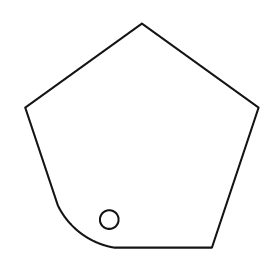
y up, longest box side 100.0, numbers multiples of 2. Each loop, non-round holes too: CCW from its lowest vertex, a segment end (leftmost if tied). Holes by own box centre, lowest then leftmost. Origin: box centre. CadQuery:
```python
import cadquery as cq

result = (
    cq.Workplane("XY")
    .moveTo(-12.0, -48.0)
    .lineTo(30.0, -48.0)
    .lineTo(50.0, 12.0)
    .lineTo(0.0, 48.0)
    .lineTo(-50.0, 12.0)
    .lineTo(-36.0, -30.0)
    .threePointArc((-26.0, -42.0), (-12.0, -48.0))
    .close()
    .moveTo(-14.0, -36.0)
    .circle(4.0)
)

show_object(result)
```